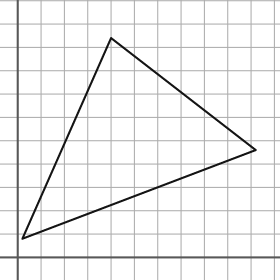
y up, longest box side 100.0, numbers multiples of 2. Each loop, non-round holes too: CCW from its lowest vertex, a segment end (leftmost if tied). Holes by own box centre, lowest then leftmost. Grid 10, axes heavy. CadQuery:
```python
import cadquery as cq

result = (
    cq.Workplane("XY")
    .moveTo(2.0, 8.0)
    .lineTo(102.0, 46.0)
    .lineTo(40.0, 94.0)
    .close()
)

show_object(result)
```